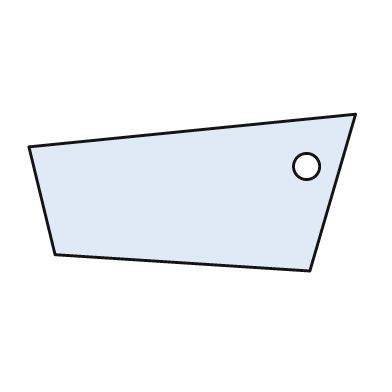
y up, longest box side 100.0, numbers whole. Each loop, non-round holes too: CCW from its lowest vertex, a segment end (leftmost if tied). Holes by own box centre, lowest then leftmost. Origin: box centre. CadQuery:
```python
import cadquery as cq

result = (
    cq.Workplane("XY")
    .moveTo(36.0, -24.0)
    .lineTo(50.0, 24.0)
    .lineTo(-50.0, 14.0)
    .lineTo(-42.0, -19.0)
    .close()
    .moveTo(35.0, 8.0)
    .circle(4.0)
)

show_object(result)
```